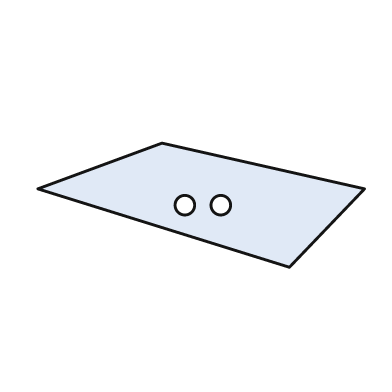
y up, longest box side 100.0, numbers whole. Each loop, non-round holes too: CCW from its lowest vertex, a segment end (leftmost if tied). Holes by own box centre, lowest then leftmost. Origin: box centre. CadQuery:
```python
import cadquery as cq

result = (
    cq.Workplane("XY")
    .moveTo(27.0, -19.0)
    .lineTo(50.0, 5.0)
    .lineTo(-12.0, 19.0)
    .lineTo(-50.0, 5.0)
    .close()
    .moveTo(-5.0, 0.0)
    .circle(3.0)
    .moveTo(6.0, 0.0)
    .circle(3.0)
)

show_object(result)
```